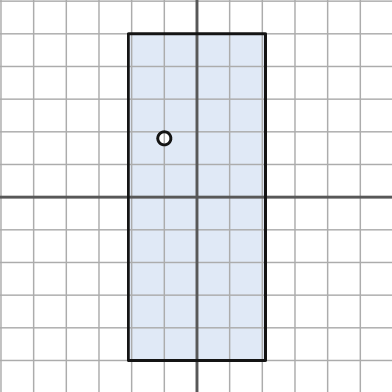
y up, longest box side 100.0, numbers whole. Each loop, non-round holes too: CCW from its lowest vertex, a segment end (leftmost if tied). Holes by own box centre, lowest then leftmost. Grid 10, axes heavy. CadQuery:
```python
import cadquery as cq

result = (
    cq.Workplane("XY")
    .moveTo(-21.0, -50.0)
    .lineTo(21.0, -50.0)
    .lineTo(21.0, 50.0)
    .lineTo(-21.0, 50.0)
    .close()
    .moveTo(-10.0, 18.0)
    .circle(2.0)
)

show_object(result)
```